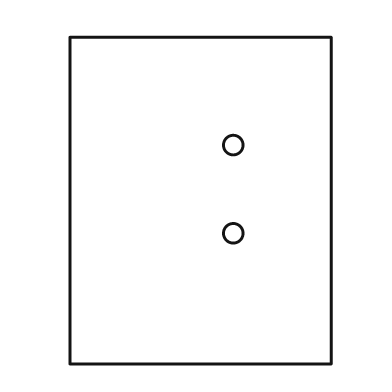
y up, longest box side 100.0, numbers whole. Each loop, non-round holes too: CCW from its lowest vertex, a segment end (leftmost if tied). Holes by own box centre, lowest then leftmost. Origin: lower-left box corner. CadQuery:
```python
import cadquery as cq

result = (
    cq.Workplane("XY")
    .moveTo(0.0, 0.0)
    .lineTo(80.0, 0.0)
    .lineTo(80.0, 100.0)
    .lineTo(0.0, 100.0)
    .close()
    .moveTo(50.0, 40.0)
    .circle(3.0)
    .moveTo(50.0, 67.0)
    .circle(3.0)
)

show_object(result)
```